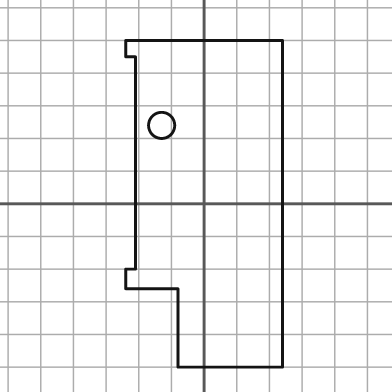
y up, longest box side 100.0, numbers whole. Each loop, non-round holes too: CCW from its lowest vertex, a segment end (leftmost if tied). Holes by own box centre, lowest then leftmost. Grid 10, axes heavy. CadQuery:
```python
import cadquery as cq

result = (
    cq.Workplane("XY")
    .moveTo(-8.0, -50.0)
    .lineTo(24.0, -50.0)
    .lineTo(24.0, 50.0)
    .lineTo(-24.0, 50.0)
    .lineTo(-24.0, 45.0)
    .lineTo(-21.0, 45.0)
    .lineTo(-21.0, -20.0)
    .lineTo(-24.0, -20.0)
    .lineTo(-24.0, -26.0)
    .lineTo(-8.0, -26.0)
    .close()
    .moveTo(-13.0, 24.0)
    .circle(4.0)
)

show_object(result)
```